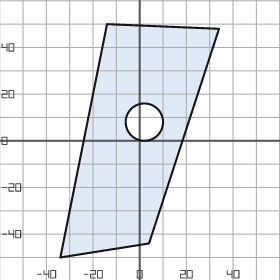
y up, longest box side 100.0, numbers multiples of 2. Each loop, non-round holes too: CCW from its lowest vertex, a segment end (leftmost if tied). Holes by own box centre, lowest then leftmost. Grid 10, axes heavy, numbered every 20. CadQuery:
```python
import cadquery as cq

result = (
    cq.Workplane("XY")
    .moveTo(-34.0, -50.0)
    .lineTo(4.0, -44.0)
    .lineTo(34.0, 48.0)
    .lineTo(-14.0, 50.0)
    .close()
    .moveTo(2.0, 8.0)
    .circle(8.0)
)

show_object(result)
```